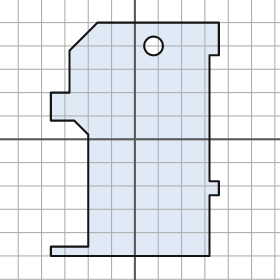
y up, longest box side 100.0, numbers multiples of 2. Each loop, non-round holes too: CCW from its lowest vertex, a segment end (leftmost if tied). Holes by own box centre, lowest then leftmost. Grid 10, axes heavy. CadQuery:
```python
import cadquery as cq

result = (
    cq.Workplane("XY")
    .moveTo(-36.0, -50.0)
    .lineTo(32.0, -50.0)
    .lineTo(32.0, -24.0)
    .lineTo(36.0, -24.0)
    .lineTo(36.0, -18.0)
    .lineTo(32.0, -18.0)
    .lineTo(32.0, 36.0)
    .lineTo(36.0, 36.0)
    .lineTo(36.0, 50.0)
    .lineTo(-16.0, 50.0)
    .lineTo(-28.0, 38.0)
    .lineTo(-28.0, 20.0)
    .lineTo(-36.0, 20.0)
    .lineTo(-36.0, 8.0)
    .lineTo(-26.0, 8.0)
    .lineTo(-20.0, 2.0)
    .lineTo(-20.0, -46.0)
    .lineTo(-36.0, -46.0)
    .close()
    .moveTo(8.0, 40.0)
    .circle(4.0)
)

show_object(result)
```